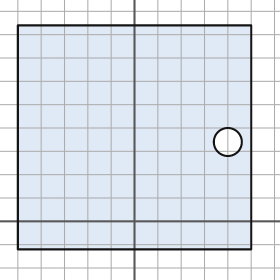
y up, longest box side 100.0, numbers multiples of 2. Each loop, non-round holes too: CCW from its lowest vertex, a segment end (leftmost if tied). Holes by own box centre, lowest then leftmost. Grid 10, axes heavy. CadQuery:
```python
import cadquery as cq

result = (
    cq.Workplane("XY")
    .moveTo(-50.0, -12.0)
    .lineTo(50.0, -12.0)
    .lineTo(50.0, 84.0)
    .lineTo(-50.0, 84.0)
    .close()
    .moveTo(40.0, 34.0)
    .circle(6.0)
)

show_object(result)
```